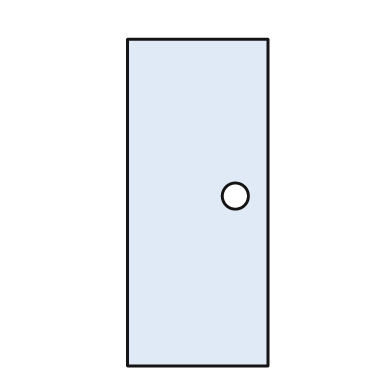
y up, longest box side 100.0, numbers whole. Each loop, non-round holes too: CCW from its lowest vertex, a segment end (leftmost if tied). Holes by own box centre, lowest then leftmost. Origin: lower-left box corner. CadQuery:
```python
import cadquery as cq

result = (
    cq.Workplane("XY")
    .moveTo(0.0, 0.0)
    .lineTo(43.0, 0.0)
    .lineTo(43.0, 100.0)
    .lineTo(0.0, 100.0)
    .close()
    .moveTo(33.0, 52.0)
    .circle(4.0)
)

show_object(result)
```